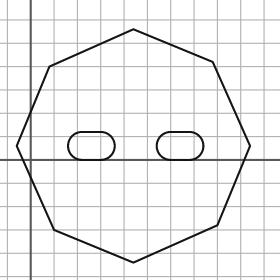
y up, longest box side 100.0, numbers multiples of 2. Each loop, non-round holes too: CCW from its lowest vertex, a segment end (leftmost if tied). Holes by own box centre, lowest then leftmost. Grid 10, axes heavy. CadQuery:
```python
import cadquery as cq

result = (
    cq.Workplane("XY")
    .moveTo(44.0, -44.0)
    .lineTo(80.0, -28.0)
    .lineTo(94.0, 6.0)
    .lineTo(78.0, 42.0)
    .lineTo(44.0, 56.0)
    .lineTo(8.0, 40.0)
    .lineTo(-6.0, 6.0)
    .lineTo(10.0, -30.0)
    .close()
    .moveTo(22.0, 0.0)
    .lineTo(30.0, 0.0)
    .threePointArc((36.0, 6.0), (30.0, 12.0))
    .lineTo(22.0, 12.0)
    .threePointArc((16.0, 6.0), (22.0, 0.0))
    .close()
    .moveTo(60.0, 0.0)
    .lineTo(68.0, 0.0)
    .threePointArc((74.0, 6.0), (68.0, 12.0))
    .lineTo(60.0, 12.0)
    .threePointArc((54.0, 6.0), (60.0, 0.0))
    .close()
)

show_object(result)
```